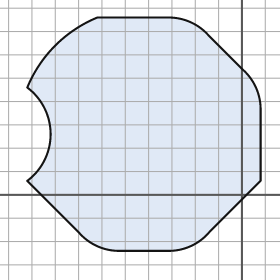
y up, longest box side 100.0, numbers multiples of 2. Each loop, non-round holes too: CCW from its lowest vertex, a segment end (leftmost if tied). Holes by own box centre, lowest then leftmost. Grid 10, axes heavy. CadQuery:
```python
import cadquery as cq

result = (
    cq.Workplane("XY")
    .moveTo(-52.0, -24.0)
    .lineTo(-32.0, -24.0)
    .threePointArc((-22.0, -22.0), (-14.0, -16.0))
    .lineTo(8.0, 6.0)
    .lineTo(8.0, 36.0)
    .threePointArc((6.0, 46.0), (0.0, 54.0))
    .lineTo(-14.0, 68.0)
    .threePointArc((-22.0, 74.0), (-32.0, 76.0))
    .lineTo(-62.0, 76.0)
    .threePointArc((-80.0, 64.0), (-92.0, 46.0))
    .threePointArc((-82.0, 26.0), (-92.0, 6.0))
    .lineTo(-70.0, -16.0)
    .threePointArc((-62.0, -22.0), (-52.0, -24.0))
    .close()
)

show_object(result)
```